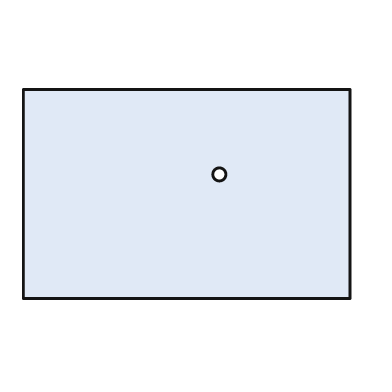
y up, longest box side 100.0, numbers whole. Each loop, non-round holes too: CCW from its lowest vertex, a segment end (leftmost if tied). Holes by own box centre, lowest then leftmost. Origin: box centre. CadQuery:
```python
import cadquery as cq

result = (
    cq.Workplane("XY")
    .moveTo(-50.0, -32.0)
    .lineTo(50.0, -32.0)
    .lineTo(50.0, 32.0)
    .lineTo(-50.0, 32.0)
    .close()
    .moveTo(10.0, 6.0)
    .circle(2.0)
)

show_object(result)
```